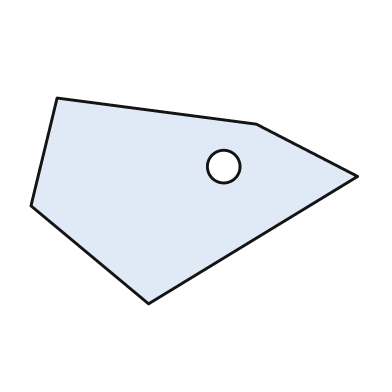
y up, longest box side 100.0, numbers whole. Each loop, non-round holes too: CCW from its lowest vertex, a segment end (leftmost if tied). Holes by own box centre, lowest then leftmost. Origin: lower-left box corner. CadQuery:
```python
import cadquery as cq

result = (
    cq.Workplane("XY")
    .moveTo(36.0, 0.0)
    .lineTo(100.0, 39.0)
    .lineTo(69.0, 55.0)
    .lineTo(8.0, 63.0)
    .lineTo(0.0, 30.0)
    .close()
    .moveTo(59.0, 42.0)
    .circle(5.0)
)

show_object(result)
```